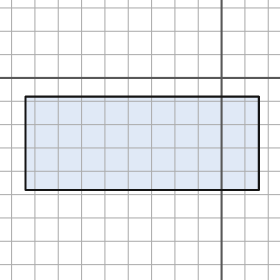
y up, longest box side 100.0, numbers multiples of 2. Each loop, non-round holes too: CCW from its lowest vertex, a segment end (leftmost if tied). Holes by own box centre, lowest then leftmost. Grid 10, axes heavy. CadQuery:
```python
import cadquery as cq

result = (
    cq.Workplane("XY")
    .moveTo(-84.0, -48.0)
    .lineTo(16.0, -48.0)
    .lineTo(16.0, -8.0)
    .lineTo(-84.0, -8.0)
    .close()
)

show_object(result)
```